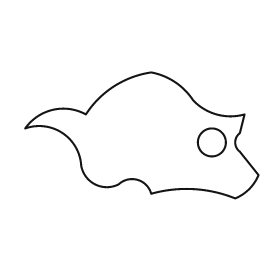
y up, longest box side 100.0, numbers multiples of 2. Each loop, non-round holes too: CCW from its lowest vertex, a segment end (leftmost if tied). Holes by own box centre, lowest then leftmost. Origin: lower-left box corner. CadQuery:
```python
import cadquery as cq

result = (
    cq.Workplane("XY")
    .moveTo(90.0, 0.0)
    .threePointArc((96.0, 4.0), (100.0, 10.0))
    .lineTo(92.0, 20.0)
    .threePointArc((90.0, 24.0), (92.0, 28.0))
    .lineTo(94.0, 36.0)
    .threePointArc((82.0, 36.0), (72.0, 42.0))
    .threePointArc((64.0, 50.0), (54.0, 54.0))
    .threePointArc((38.0, 48.0), (26.0, 36.0))
    .threePointArc((12.0, 38.0), (0.0, 30.0))
    .threePointArc((16.0, 28.0), (24.0, 14.0))
    .threePointArc((30.0, 6.0), (40.0, 6.0))
    .threePointArc((48.0, 8.0), (54.0, 2.0))
    .threePointArc((72.0, 4.0), (90.0, 0.0))
    .close()
    .moveTo(80.0, 24.0)
    .circle(6.0)
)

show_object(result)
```